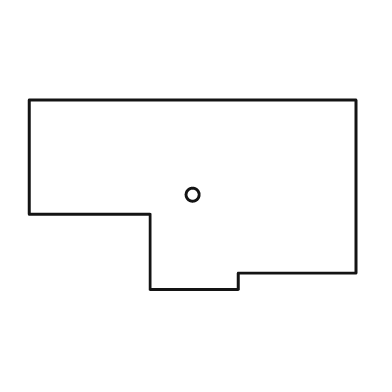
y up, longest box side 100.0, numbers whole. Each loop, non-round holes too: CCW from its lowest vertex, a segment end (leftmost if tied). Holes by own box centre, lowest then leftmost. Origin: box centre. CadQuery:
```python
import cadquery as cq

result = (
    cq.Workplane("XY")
    .moveTo(-13.0, -29.0)
    .lineTo(14.0, -29.0)
    .lineTo(14.0, -24.0)
    .lineTo(50.0, -24.0)
    .lineTo(50.0, 29.0)
    .lineTo(-50.0, 29.0)
    .lineTo(-50.0, -6.0)
    .lineTo(-13.0, -6.0)
    .close()
    .moveTo(0.0, 0.0)
    .circle(2.0)
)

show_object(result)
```